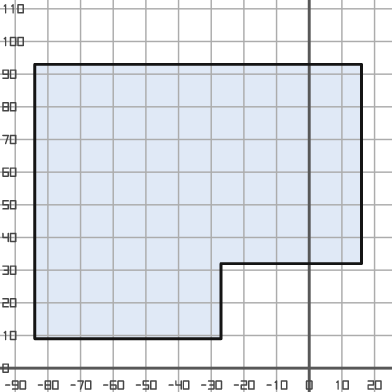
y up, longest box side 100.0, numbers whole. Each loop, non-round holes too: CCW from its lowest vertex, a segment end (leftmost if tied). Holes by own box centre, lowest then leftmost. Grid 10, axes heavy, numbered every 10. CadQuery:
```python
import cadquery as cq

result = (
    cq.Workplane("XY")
    .moveTo(-84.0, 9.0)
    .lineTo(-27.0, 9.0)
    .lineTo(-27.0, 32.0)
    .lineTo(16.0, 32.0)
    .lineTo(16.0, 93.0)
    .lineTo(-84.0, 93.0)
    .close()
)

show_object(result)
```